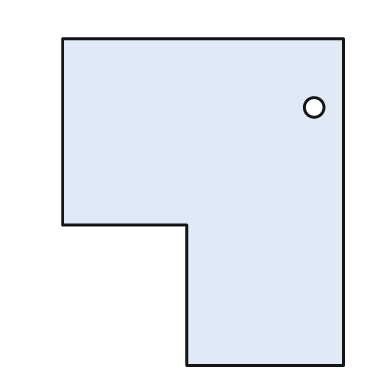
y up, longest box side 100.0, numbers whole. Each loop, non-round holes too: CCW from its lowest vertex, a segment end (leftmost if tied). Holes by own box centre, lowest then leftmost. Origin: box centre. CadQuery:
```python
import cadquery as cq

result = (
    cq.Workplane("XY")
    .moveTo(-5.0, -50.0)
    .lineTo(43.0, -50.0)
    .lineTo(43.0, 50.0)
    .lineTo(-43.0, 50.0)
    .lineTo(-43.0, -7.0)
    .lineTo(-5.0, -7.0)
    .close()
    .moveTo(34.0, 29.0)
    .circle(3.0)
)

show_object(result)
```